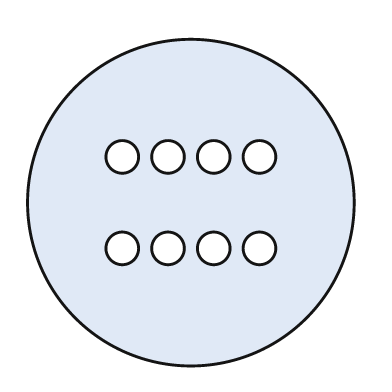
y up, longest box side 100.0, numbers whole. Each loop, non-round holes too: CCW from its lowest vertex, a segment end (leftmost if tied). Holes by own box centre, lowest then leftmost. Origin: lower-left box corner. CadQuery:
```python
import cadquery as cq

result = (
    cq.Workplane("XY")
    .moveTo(50.0, 50.0)
    .circle(50.0)
    .moveTo(29.0, 36.0)
    .circle(5.0)
    .moveTo(43.0, 36.0)
    .circle(5.0)
    .moveTo(57.0, 36.0)
    .circle(5.0)
    .moveTo(71.0, 36.0)
    .circle(5.0)
    .moveTo(29.0, 64.0)
    .circle(5.0)
    .moveTo(43.0, 64.0)
    .circle(5.0)
    .moveTo(57.0, 64.0)
    .circle(5.0)
    .moveTo(71.0, 64.0)
    .circle(5.0)
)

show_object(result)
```